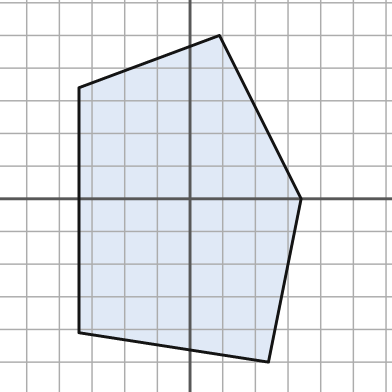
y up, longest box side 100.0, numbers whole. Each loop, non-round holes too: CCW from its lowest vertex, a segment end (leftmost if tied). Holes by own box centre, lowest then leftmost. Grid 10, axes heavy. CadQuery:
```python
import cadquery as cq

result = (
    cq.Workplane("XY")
    .moveTo(24.0, -50.0)
    .lineTo(34.0, 0.0)
    .lineTo(9.0, 50.0)
    .lineTo(-34.0, 34.0)
    .lineTo(-34.0, -41.0)
    .close()
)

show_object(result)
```